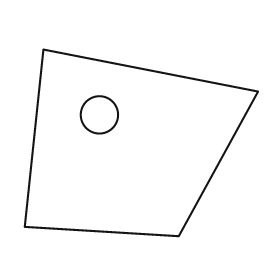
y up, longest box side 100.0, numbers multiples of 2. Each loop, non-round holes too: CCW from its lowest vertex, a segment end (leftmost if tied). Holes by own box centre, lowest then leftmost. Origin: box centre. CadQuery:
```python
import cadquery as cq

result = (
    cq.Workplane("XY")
    .moveTo(16.0, -40.0)
    .lineTo(50.0, 22.0)
    .lineTo(-42.0, 40.0)
    .lineTo(-50.0, -36.0)
    .close()
    .moveTo(-18.0, 12.0)
    .circle(8.0)
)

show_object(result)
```